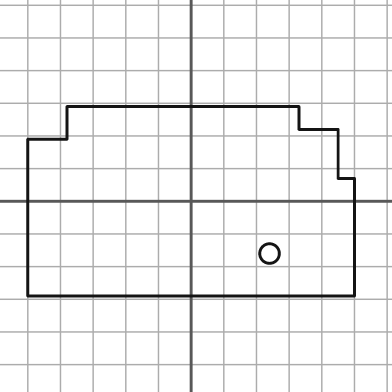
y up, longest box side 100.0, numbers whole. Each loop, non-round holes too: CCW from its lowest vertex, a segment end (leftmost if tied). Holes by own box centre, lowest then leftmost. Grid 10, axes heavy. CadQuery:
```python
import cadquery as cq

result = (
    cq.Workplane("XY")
    .moveTo(-50.0, -29.0)
    .lineTo(50.0, -29.0)
    .lineTo(50.0, 7.0)
    .lineTo(45.0, 7.0)
    .lineTo(45.0, 22.0)
    .lineTo(33.0, 22.0)
    .lineTo(33.0, 29.0)
    .lineTo(-38.0, 29.0)
    .lineTo(-38.0, 19.0)
    .lineTo(-50.0, 19.0)
    .close()
    .moveTo(24.0, -16.0)
    .circle(3.0)
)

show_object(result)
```